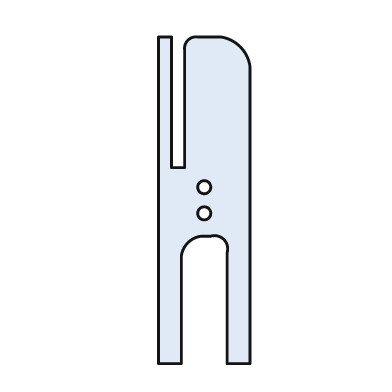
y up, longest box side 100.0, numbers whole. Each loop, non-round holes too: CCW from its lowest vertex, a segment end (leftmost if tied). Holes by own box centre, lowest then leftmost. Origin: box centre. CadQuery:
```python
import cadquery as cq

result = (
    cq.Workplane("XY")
    .moveTo(-14.0, -50.0)
    .lineTo(-7.0, -50.0)
    .lineTo(-7.0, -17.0)
    .threePointArc((-5.0, -13.0), (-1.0, -11.0))
    .lineTo(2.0, -11.0)
    .threePointArc((6.0, -12.0), (7.0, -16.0))
    .lineTo(7.0, -50.0)
    .lineTo(14.0, -50.0)
    .lineTo(14.0, 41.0)
    .threePointArc((11.0, 47.0), (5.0, 50.0))
    .lineTo(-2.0, 50.0)
    .threePointArc((-5.0, 49.0), (-6.0, 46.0))
    .lineTo(-6.0, 10.0)
    .lineTo(-10.0, 10.0)
    .lineTo(-10.0, 50.0)
    .lineTo(-14.0, 50.0)
    .close()
    .moveTo(0.0, -4.0)
    .circle(2.0)
    .moveTo(0.0, 4.0)
    .circle(2.0)
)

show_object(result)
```